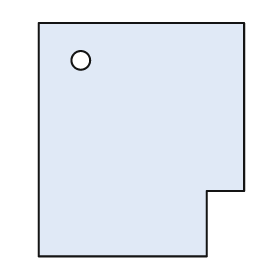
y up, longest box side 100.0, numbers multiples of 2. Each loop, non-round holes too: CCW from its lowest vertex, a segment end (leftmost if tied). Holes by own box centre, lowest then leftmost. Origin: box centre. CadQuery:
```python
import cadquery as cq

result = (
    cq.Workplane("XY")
    .moveTo(-44.0, -50.0)
    .lineTo(28.0, -50.0)
    .lineTo(28.0, -22.0)
    .lineTo(44.0, -22.0)
    .lineTo(44.0, 50.0)
    .lineTo(-44.0, 50.0)
    .close()
    .moveTo(-26.0, 34.0)
    .circle(4.0)
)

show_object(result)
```